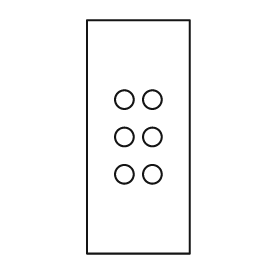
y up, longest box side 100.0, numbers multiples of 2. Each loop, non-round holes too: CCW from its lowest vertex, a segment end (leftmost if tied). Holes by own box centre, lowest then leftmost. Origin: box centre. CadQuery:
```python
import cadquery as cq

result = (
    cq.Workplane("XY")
    .moveTo(-22.0, -50.0)
    .lineTo(22.0, -50.0)
    .lineTo(22.0, 50.0)
    .lineTo(-22.0, 50.0)
    .close()
    .moveTo(-6.0, -16.0)
    .circle(4.0)
    .moveTo(6.0, -16.0)
    .circle(4.0)
    .moveTo(-6.0, 0.0)
    .circle(4.0)
    .moveTo(6.0, 0.0)
    .circle(4.0)
    .moveTo(-6.0, 16.0)
    .circle(4.0)
    .moveTo(6.0, 16.0)
    .circle(4.0)
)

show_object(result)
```